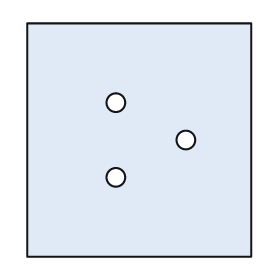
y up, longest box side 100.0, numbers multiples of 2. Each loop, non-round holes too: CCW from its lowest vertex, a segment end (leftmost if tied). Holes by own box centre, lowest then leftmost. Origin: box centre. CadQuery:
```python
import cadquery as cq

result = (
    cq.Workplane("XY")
    .moveTo(-48.0, -50.0)
    .lineTo(48.0, -50.0)
    .lineTo(48.0, 50.0)
    .lineTo(-48.0, 50.0)
    .close()
    .moveTo(-10.0, -16.0)
    .circle(4.0)
    .moveTo(20.0, 0.0)
    .circle(4.0)
    .moveTo(-10.0, 16.0)
    .circle(4.0)
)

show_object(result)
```